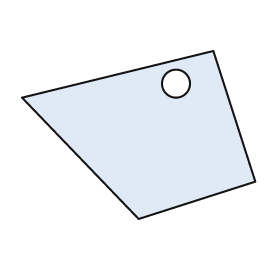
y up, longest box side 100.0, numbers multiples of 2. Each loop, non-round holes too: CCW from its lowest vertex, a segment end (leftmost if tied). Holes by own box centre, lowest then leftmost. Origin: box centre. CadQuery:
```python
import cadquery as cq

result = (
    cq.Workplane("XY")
    .moveTo(0.0, -36.0)
    .lineTo(50.0, -20.0)
    .lineTo(32.0, 36.0)
    .lineTo(-50.0, 16.0)
    .close()
    .moveTo(16.0, 22.0)
    .circle(6.0)
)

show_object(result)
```